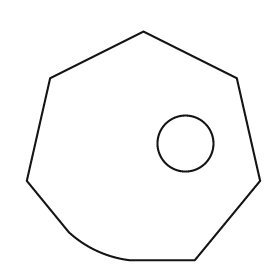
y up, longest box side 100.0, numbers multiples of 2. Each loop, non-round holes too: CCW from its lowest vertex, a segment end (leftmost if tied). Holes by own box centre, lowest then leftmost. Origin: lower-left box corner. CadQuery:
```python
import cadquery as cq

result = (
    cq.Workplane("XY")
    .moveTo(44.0, 0.0)
    .lineTo(72.0, 0.0)
    .lineTo(100.0, 34.0)
    .lineTo(90.0, 78.0)
    .lineTo(50.0, 98.0)
    .lineTo(10.0, 78.0)
    .lineTo(0.0, 34.0)
    .lineTo(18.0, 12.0)
    .threePointArc((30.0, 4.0), (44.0, 0.0))
    .close()
    .moveTo(68.0, 50.0)
    .circle(12.0)
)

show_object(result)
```